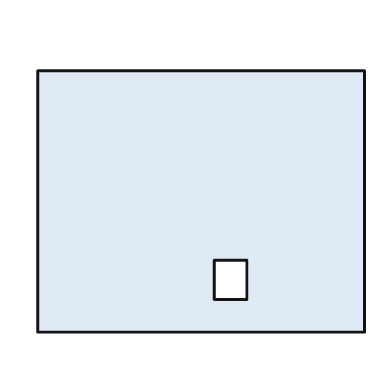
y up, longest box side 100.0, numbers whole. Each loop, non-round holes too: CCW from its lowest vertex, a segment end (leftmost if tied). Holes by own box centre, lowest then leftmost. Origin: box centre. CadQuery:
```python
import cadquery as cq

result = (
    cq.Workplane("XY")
    .moveTo(-50.0, -40.0)
    .lineTo(50.0, -40.0)
    .lineTo(50.0, 40.0)
    .lineTo(-50.0, 40.0)
    .close()
    .moveTo(4.0, -30.0)
    .lineTo(14.0, -30.0)
    .lineTo(14.0, -18.0)
    .lineTo(4.0, -18.0)
    .close()
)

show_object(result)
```